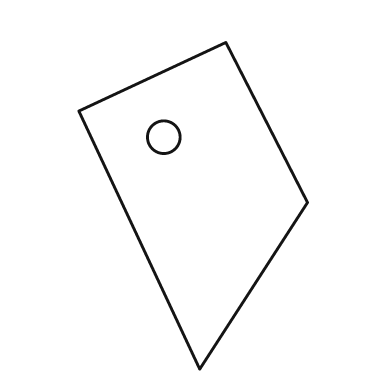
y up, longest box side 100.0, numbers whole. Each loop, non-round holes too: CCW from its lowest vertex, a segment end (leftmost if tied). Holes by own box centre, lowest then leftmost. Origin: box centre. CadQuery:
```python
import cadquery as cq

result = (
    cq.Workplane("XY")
    .moveTo(2.0, -50.0)
    .lineTo(35.0, 1.0)
    .lineTo(10.0, 50.0)
    .lineTo(-35.0, 29.0)
    .close()
    .moveTo(-9.0, 21.0)
    .circle(5.0)
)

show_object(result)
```